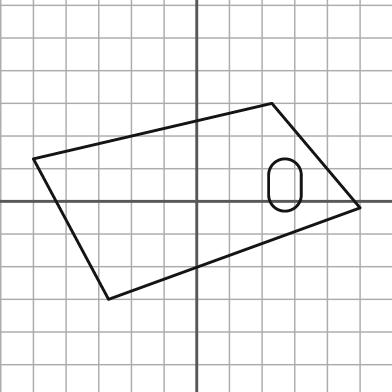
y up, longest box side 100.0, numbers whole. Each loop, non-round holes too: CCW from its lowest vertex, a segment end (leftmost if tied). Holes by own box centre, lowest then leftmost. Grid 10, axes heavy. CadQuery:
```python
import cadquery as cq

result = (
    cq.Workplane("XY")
    .moveTo(-27.0, -30.0)
    .lineTo(50.0, -2.0)
    .lineTo(23.0, 30.0)
    .lineTo(-50.0, 13.0)
    .close()
    .moveTo(22.0, 2.0)
    .threePointArc((27.0, -3.0), (32.0, 2.0))
    .lineTo(32.0, 8.0)
    .threePointArc((27.0, 13.0), (22.0, 8.0))
    .close()
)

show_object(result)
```